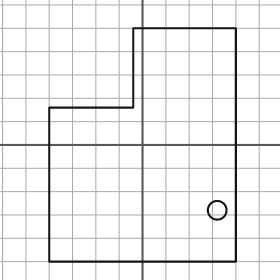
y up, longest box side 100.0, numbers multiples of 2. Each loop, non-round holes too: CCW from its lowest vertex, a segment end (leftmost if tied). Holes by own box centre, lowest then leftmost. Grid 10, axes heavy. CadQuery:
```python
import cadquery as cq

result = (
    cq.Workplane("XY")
    .moveTo(-40.0, -50.0)
    .lineTo(40.0, -50.0)
    .lineTo(40.0, 50.0)
    .lineTo(-4.0, 50.0)
    .lineTo(-4.0, 16.0)
    .lineTo(-40.0, 16.0)
    .close()
    .moveTo(32.0, -28.0)
    .circle(4.0)
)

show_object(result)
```